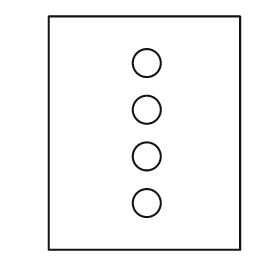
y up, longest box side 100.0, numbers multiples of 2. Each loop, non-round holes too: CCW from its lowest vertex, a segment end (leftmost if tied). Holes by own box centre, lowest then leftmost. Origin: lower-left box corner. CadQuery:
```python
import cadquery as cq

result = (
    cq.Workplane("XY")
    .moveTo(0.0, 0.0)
    .lineTo(82.0, 0.0)
    .lineTo(82.0, 100.0)
    .lineTo(0.0, 100.0)
    .close()
    .moveTo(42.0, 20.0)
    .circle(6.0)
    .moveTo(42.0, 40.0)
    .circle(6.0)
    .moveTo(42.0, 60.0)
    .circle(6.0)
    .moveTo(42.0, 80.0)
    .circle(6.0)
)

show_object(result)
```